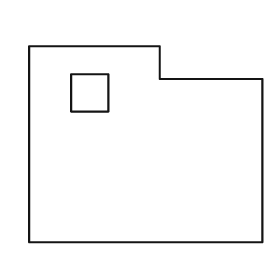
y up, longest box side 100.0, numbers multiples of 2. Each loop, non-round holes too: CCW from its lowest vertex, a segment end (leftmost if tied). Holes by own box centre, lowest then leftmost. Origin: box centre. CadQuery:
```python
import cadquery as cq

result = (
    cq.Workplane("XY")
    .moveTo(-50.0, -42.0)
    .lineTo(50.0, -42.0)
    .lineTo(50.0, 28.0)
    .lineTo(6.0, 28.0)
    .lineTo(6.0, 42.0)
    .lineTo(-50.0, 42.0)
    .close()
    .moveTo(-32.0, 14.0)
    .lineTo(-16.0, 14.0)
    .lineTo(-16.0, 30.0)
    .lineTo(-32.0, 30.0)
    .close()
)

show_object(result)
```